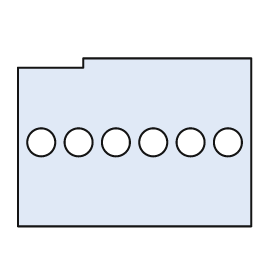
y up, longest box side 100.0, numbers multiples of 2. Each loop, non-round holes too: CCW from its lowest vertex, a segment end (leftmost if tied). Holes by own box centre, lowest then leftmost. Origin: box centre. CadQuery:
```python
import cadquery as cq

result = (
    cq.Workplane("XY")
    .moveTo(-50.0, -36.0)
    .lineTo(50.0, -36.0)
    .lineTo(50.0, 36.0)
    .lineTo(-22.0, 36.0)
    .lineTo(-22.0, 32.0)
    .lineTo(-50.0, 32.0)
    .close()
    .moveTo(-40.0, 0.0)
    .circle(6.0)
    .moveTo(-24.0, 0.0)
    .circle(6.0)
    .moveTo(-8.0, 0.0)
    .circle(6.0)
    .moveTo(8.0, 0.0)
    .circle(6.0)
    .moveTo(24.0, 0.0)
    .circle(6.0)
    .moveTo(40.0, 0.0)
    .circle(6.0)
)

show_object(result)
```